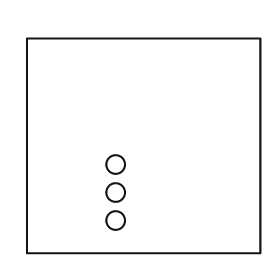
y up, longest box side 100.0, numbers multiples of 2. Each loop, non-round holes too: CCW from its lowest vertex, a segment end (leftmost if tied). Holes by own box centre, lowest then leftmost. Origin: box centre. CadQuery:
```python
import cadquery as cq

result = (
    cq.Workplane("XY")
    .moveTo(-50.0, -46.0)
    .lineTo(50.0, -46.0)
    .lineTo(50.0, 46.0)
    .lineTo(-50.0, 46.0)
    .close()
    .moveTo(-12.0, -32.0)
    .circle(4.0)
    .moveTo(-12.0, -20.0)
    .circle(4.0)
    .moveTo(-12.0, -8.0)
    .circle(4.0)
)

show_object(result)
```